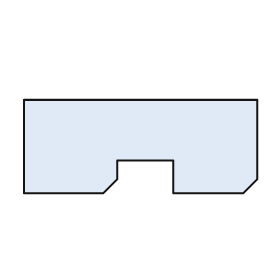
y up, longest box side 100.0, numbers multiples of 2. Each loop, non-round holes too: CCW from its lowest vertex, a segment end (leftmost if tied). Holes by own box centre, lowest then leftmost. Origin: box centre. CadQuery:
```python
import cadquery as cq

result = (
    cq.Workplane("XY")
    .moveTo(-50.0, -20.0)
    .lineTo(-16.0, -20.0)
    .lineTo(-10.0, -14.0)
    .lineTo(-10.0, -6.0)
    .lineTo(14.0, -6.0)
    .lineTo(14.0, -20.0)
    .lineTo(44.0, -20.0)
    .lineTo(50.0, -14.0)
    .lineTo(50.0, 20.0)
    .lineTo(-50.0, 20.0)
    .close()
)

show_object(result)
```